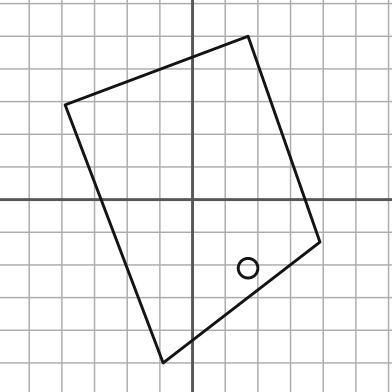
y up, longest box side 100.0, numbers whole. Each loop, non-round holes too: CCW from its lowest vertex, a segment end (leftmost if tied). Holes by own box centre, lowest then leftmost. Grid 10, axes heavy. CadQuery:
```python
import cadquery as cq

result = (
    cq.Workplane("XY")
    .moveTo(-9.0, -50.0)
    .lineTo(39.0, -13.0)
    .lineTo(17.0, 50.0)
    .lineTo(-39.0, 29.0)
    .close()
    .moveTo(17.0, -21.0)
    .circle(3.0)
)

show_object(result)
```